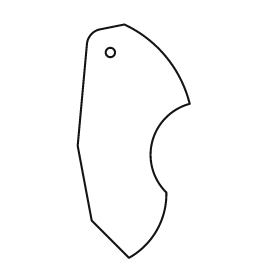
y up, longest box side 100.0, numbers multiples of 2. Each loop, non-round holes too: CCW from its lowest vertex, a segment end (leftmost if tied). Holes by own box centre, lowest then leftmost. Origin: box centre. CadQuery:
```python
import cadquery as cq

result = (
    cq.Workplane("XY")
    .moveTo(-2.0, -50.0)
    .threePointArc((10.0, -38.0), (14.0, -22.0))
    .threePointArc((8.0, 0.0), (24.0, 16.0))
    .threePointArc((14.0, 36.0), (-4.0, 50.0))
    .lineTo(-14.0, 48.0)
    .threePointArc((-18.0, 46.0), (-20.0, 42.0))
    .lineTo(-24.0, -2.0)
    .lineTo(-18.0, -34.0)
    .close()
    .moveTo(-10.0, 38.0)
    .circle(2.0)
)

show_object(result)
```